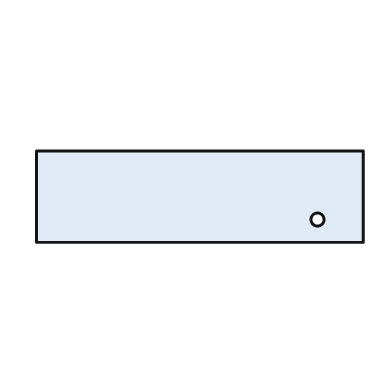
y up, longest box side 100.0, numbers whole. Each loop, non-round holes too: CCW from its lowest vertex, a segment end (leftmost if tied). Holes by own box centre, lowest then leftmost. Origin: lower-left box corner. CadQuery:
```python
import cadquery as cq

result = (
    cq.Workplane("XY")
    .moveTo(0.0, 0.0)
    .lineTo(100.0, 0.0)
    .lineTo(100.0, 28.0)
    .lineTo(0.0, 28.0)
    .close()
    .moveTo(86.0, 7.0)
    .circle(2.0)
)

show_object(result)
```